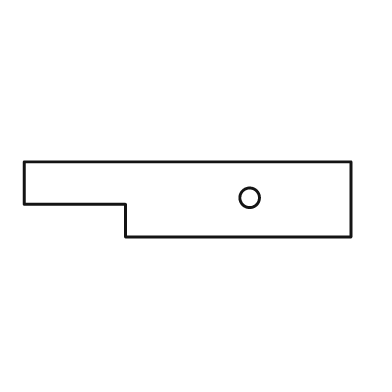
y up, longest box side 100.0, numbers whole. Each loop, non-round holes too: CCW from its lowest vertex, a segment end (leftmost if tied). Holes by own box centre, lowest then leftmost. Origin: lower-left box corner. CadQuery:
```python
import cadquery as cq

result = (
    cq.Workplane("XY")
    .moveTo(31.0, 0.0)
    .lineTo(100.0, 0.0)
    .lineTo(100.0, 23.0)
    .lineTo(0.0, 23.0)
    .lineTo(0.0, 10.0)
    .lineTo(31.0, 10.0)
    .close()
    .moveTo(69.0, 12.0)
    .circle(3.0)
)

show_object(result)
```